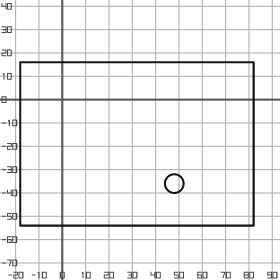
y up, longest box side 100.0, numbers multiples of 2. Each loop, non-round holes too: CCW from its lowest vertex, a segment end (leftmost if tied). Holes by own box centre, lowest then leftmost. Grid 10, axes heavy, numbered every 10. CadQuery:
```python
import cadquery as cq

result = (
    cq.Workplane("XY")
    .moveTo(-18.0, -54.0)
    .lineTo(82.0, -54.0)
    .lineTo(82.0, 16.0)
    .lineTo(-18.0, 16.0)
    .close()
    .moveTo(48.0, -36.0)
    .circle(4.0)
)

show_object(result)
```